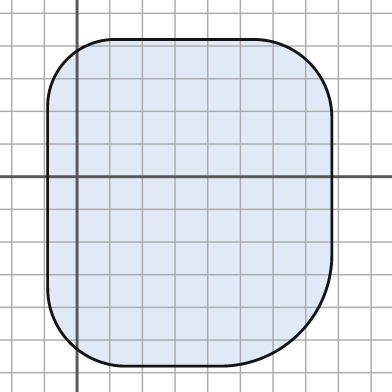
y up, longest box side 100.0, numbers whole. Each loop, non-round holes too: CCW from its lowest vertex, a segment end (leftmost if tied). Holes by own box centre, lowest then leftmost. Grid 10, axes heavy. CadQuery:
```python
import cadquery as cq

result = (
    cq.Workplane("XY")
    .moveTo(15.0, -58.0)
    .lineTo(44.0, -58.0)
    .threePointArc((68.0, -48.0), (78.0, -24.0))
    .lineTo(78.0, 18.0)
    .threePointArc((71.0, 35.0), (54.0, 42.0))
    .lineTo(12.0, 42.0)
    .threePointArc((-3.0, 36.0), (-9.0, 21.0))
    .lineTo(-9.0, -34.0)
    .threePointArc((-2.0, -51.0), (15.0, -58.0))
    .close()
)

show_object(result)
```